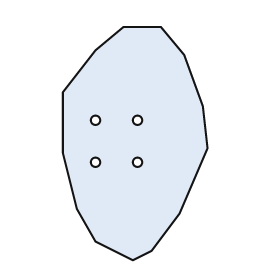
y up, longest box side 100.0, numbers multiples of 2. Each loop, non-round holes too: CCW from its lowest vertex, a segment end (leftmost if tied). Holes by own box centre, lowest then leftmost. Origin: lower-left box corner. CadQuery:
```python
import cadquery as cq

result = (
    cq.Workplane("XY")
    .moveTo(30.0, 0.0)
    .lineTo(38.0, 4.0)
    .lineTo(50.0, 20.0)
    .lineTo(62.0, 48.0)
    .lineTo(60.0, 66.0)
    .lineTo(52.0, 88.0)
    .lineTo(42.0, 100.0)
    .lineTo(26.0, 100.0)
    .lineTo(14.0, 90.0)
    .lineTo(0.0, 72.0)
    .lineTo(0.0, 46.0)
    .lineTo(6.0, 22.0)
    .lineTo(14.0, 8.0)
    .close()
    .moveTo(14.0, 42.0)
    .circle(2.0)
    .moveTo(32.0, 42.0)
    .circle(2.0)
    .moveTo(14.0, 60.0)
    .circle(2.0)
    .moveTo(32.0, 60.0)
    .circle(2.0)
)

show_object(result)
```